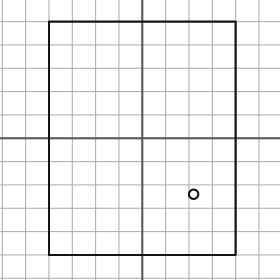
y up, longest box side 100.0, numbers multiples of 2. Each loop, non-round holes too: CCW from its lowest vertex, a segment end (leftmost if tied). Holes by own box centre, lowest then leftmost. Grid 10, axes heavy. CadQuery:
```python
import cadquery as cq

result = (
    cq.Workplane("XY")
    .moveTo(-40.0, -50.0)
    .lineTo(40.0, -50.0)
    .lineTo(40.0, 50.0)
    .lineTo(-40.0, 50.0)
    .close()
    .moveTo(22.0, -24.0)
    .circle(2.0)
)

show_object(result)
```